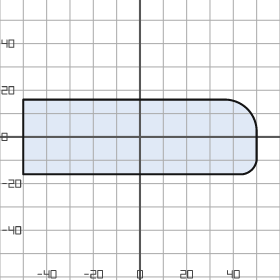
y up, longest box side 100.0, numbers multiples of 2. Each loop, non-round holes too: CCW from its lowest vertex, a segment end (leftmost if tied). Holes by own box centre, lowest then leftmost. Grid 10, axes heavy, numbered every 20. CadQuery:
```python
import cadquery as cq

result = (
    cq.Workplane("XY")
    .moveTo(-50.0, -16.0)
    .lineTo(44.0, -16.0)
    .threePointArc((48.0, -14.0), (50.0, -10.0))
    .lineTo(50.0, 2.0)
    .threePointArc((46.0, 12.0), (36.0, 16.0))
    .lineTo(-50.0, 16.0)
    .close()
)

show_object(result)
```